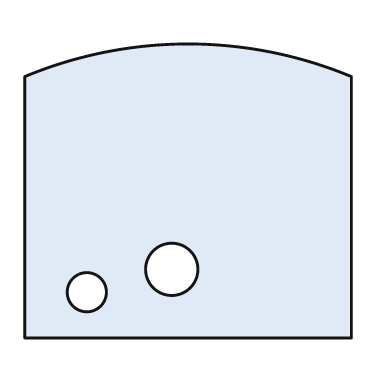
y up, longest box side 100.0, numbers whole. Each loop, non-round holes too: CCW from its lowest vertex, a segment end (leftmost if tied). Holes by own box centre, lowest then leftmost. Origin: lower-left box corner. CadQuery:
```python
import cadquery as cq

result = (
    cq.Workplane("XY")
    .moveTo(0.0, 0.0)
    .lineTo(100.0, 0.0)
    .lineTo(100.0, 80.0)
    .threePointArc((50.0, 90.0), (0.0, 80.0))
    .close()
    .moveTo(19.0, 14.0)
    .circle(6.0)
    .moveTo(45.0, 21.0)
    .circle(8.0)
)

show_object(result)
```